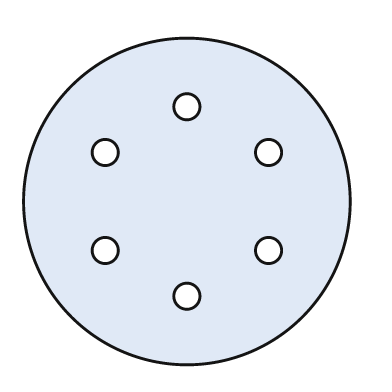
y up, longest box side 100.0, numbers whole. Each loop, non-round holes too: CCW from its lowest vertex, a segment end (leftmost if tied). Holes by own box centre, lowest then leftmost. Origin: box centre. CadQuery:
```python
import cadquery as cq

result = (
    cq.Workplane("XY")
    .moveTo(0.0, 0.0)
    .circle(50.0)
    .moveTo(0.0, -29.0)
    .circle(4.0)
    .moveTo(-25.0, -15.0)
    .circle(4.0)
    .moveTo(25.0, -15.0)
    .circle(4.0)
    .moveTo(-25.0, 15.0)
    .circle(4.0)
    .moveTo(25.0, 15.0)
    .circle(4.0)
    .moveTo(0.0, 29.0)
    .circle(4.0)
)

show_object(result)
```